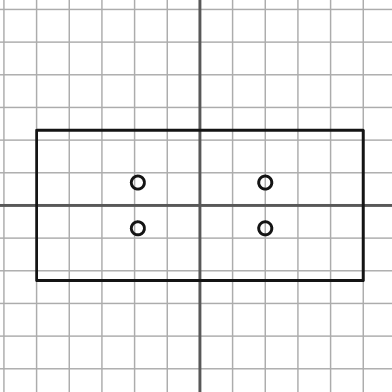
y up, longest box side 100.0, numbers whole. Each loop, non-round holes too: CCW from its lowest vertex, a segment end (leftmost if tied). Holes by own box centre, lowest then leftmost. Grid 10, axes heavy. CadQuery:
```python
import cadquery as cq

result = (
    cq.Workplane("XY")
    .moveTo(-50.0, -23.0)
    .lineTo(50.0, -23.0)
    .lineTo(50.0, 23.0)
    .lineTo(-50.0, 23.0)
    .close()
    .moveTo(-19.0, -7.0)
    .circle(2.0)
    .moveTo(20.0, -7.0)
    .circle(2.0)
    .moveTo(-19.0, 7.0)
    .circle(2.0)
    .moveTo(20.0, 7.0)
    .circle(2.0)
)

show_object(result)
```